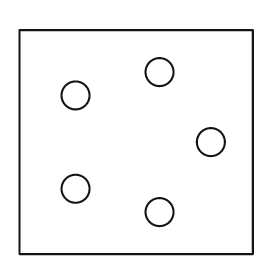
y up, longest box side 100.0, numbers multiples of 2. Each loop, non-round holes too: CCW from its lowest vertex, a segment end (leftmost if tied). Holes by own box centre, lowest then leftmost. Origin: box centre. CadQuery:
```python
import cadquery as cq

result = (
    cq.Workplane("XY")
    .moveTo(-50.0, -48.0)
    .lineTo(50.0, -48.0)
    .lineTo(50.0, 48.0)
    .lineTo(-50.0, 48.0)
    .close()
    .moveTo(10.0, -30.0)
    .circle(6.0)
    .moveTo(-26.0, -20.0)
    .circle(6.0)
    .moveTo(32.0, 0.0)
    .circle(6.0)
    .moveTo(-26.0, 20.0)
    .circle(6.0)
    .moveTo(10.0, 30.0)
    .circle(6.0)
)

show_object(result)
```